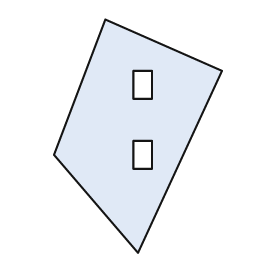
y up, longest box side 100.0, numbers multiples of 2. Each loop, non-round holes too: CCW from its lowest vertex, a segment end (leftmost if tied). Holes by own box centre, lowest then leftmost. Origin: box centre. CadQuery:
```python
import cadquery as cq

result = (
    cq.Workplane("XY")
    .moveTo(0.0, -50.0)
    .lineTo(36.0, 28.0)
    .lineTo(-14.0, 50.0)
    .lineTo(-36.0, -8.0)
    .close()
    .moveTo(-2.0, -14.0)
    .lineTo(6.0, -14.0)
    .lineTo(6.0, -2.0)
    .lineTo(-2.0, -2.0)
    .close()
    .moveTo(-2.0, 16.0)
    .lineTo(6.0, 16.0)
    .lineTo(6.0, 28.0)
    .lineTo(-2.0, 28.0)
    .close()
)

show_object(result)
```